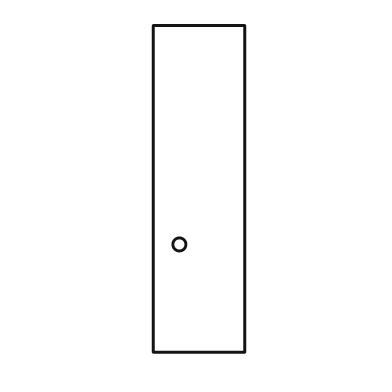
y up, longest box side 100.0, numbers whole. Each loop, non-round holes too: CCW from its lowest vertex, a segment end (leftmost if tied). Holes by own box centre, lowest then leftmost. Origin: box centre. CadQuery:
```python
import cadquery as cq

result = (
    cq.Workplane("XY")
    .moveTo(-14.0, -50.0)
    .lineTo(14.0, -50.0)
    .lineTo(14.0, 50.0)
    .lineTo(-14.0, 50.0)
    .close()
    .moveTo(-6.0, -17.0)
    .circle(2.0)
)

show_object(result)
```